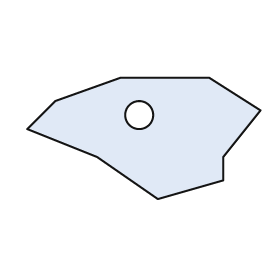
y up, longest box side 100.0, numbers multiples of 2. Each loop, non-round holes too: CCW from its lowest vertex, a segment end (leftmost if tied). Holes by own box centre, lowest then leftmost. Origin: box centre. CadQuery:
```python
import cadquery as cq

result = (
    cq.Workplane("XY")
    .moveTo(6.0, -26.0)
    .lineTo(34.0, -18.0)
    .lineTo(34.0, -8.0)
    .lineTo(50.0, 12.0)
    .lineTo(28.0, 26.0)
    .lineTo(-10.0, 26.0)
    .lineTo(-38.0, 16.0)
    .lineTo(-50.0, 4.0)
    .lineTo(-20.0, -8.0)
    .close()
    .moveTo(-2.0, 10.0)
    .circle(6.0)
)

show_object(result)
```